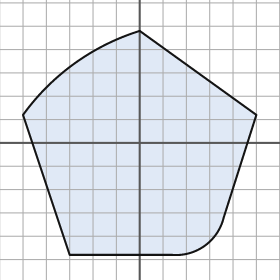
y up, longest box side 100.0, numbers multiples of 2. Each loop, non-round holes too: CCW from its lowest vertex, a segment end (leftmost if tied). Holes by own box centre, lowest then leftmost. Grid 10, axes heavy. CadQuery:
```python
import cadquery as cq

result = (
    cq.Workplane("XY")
    .moveTo(-30.0, -48.0)
    .lineTo(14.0, -48.0)
    .threePointArc((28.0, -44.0), (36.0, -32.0))
    .lineTo(50.0, 12.0)
    .lineTo(0.0, 48.0)
    .threePointArc((-28.0, 34.0), (-50.0, 12.0))
    .close()
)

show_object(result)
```